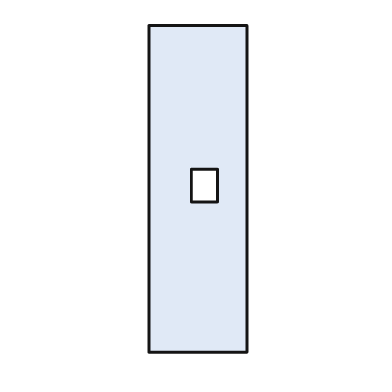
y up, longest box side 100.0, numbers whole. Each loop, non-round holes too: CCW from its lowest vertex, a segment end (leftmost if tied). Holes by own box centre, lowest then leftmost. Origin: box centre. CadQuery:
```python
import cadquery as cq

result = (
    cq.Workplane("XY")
    .moveTo(-15.0, -50.0)
    .lineTo(15.0, -50.0)
    .lineTo(15.0, 50.0)
    .lineTo(-15.0, 50.0)
    .close()
    .moveTo(-2.0, -4.0)
    .lineTo(6.0, -4.0)
    .lineTo(6.0, 6.0)
    .lineTo(-2.0, 6.0)
    .close()
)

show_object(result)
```